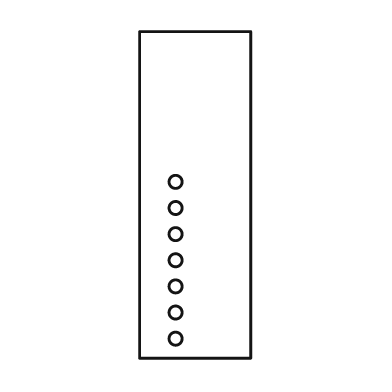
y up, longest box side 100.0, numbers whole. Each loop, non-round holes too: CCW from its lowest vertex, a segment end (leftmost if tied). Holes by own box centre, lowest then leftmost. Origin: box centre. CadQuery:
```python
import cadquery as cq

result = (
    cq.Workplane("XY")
    .moveTo(-17.0, -50.0)
    .lineTo(17.0, -50.0)
    .lineTo(17.0, 50.0)
    .lineTo(-17.0, 50.0)
    .close()
    .moveTo(-6.0, -44.0)
    .circle(2.0)
    .moveTo(-6.0, -36.0)
    .circle(2.0)
    .moveTo(-6.0, -28.0)
    .circle(2.0)
    .moveTo(-6.0, -20.0)
    .circle(2.0)
    .moveTo(-6.0, -12.0)
    .circle(2.0)
    .moveTo(-6.0, -4.0)
    .circle(2.0)
    .moveTo(-6.0, 4.0)
    .circle(2.0)
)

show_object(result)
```